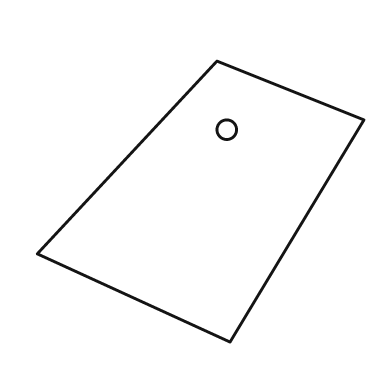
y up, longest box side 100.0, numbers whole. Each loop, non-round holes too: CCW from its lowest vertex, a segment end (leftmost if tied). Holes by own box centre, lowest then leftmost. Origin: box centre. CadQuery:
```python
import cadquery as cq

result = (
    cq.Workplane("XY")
    .moveTo(9.0, -43.0)
    .lineTo(50.0, 25.0)
    .lineTo(5.0, 43.0)
    .lineTo(-50.0, -16.0)
    .close()
    .moveTo(8.0, 22.0)
    .circle(3.0)
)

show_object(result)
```